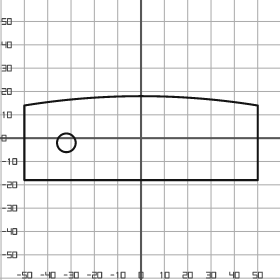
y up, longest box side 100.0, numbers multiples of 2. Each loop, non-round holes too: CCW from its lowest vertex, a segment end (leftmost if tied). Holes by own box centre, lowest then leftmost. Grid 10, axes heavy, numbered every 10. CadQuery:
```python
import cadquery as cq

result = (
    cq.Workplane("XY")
    .moveTo(-50.0, -18.0)
    .lineTo(50.0, -18.0)
    .lineTo(50.0, 14.0)
    .threePointArc((0.0, 18.0), (-50.0, 14.0))
    .close()
    .moveTo(-32.0, -2.0)
    .circle(4.0)
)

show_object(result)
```